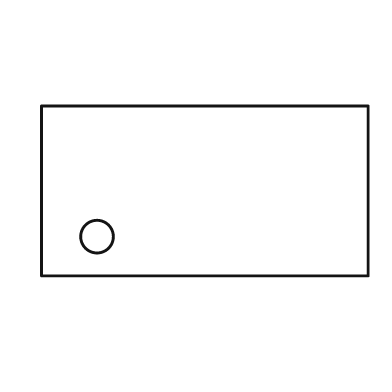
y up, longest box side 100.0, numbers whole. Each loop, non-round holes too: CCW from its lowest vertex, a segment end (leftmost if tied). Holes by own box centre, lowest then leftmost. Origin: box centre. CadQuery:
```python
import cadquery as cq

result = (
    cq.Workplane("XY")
    .moveTo(-50.0, -26.0)
    .lineTo(50.0, -26.0)
    .lineTo(50.0, 26.0)
    .lineTo(-50.0, 26.0)
    .close()
    .moveTo(-33.0, -14.0)
    .circle(5.0)
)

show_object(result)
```